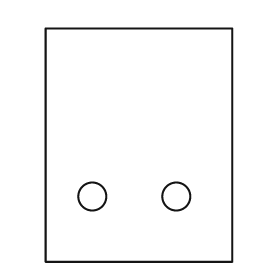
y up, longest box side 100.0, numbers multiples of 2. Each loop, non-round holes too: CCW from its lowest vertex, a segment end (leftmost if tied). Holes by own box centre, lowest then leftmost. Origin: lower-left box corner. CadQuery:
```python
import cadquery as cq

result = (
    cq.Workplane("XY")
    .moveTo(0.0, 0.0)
    .lineTo(80.0, 0.0)
    .lineTo(80.0, 100.0)
    .lineTo(0.0, 100.0)
    .close()
    .moveTo(20.0, 28.0)
    .circle(6.0)
    .moveTo(56.0, 28.0)
    .circle(6.0)
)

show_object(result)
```